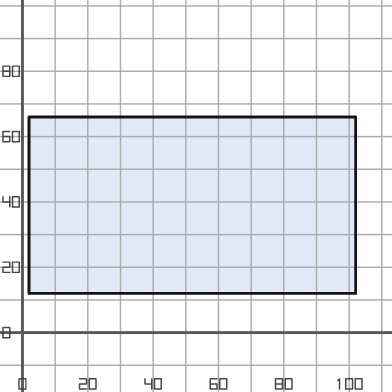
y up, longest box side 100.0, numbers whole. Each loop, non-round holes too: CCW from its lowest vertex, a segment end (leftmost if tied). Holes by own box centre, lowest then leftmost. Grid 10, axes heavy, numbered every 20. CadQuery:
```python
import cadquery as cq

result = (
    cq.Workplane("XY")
    .moveTo(2.0, 12.0)
    .lineTo(102.0, 12.0)
    .lineTo(102.0, 66.0)
    .lineTo(2.0, 66.0)
    .close()
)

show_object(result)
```